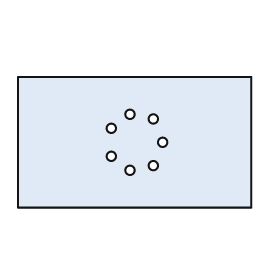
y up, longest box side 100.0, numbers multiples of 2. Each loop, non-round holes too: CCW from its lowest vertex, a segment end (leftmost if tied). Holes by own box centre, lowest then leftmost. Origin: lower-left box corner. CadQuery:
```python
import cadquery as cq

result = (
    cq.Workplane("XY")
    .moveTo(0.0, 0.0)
    .lineTo(100.0, 0.0)
    .lineTo(100.0, 56.0)
    .lineTo(0.0, 56.0)
    .close()
    .moveTo(48.0, 16.0)
    .circle(2.0)
    .moveTo(58.0, 18.0)
    .circle(2.0)
    .moveTo(40.0, 22.0)
    .circle(2.0)
    .moveTo(62.0, 28.0)
    .circle(2.0)
    .moveTo(40.0, 34.0)
    .circle(2.0)
    .moveTo(58.0, 38.0)
    .circle(2.0)
    .moveTo(48.0, 40.0)
    .circle(2.0)
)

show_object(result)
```